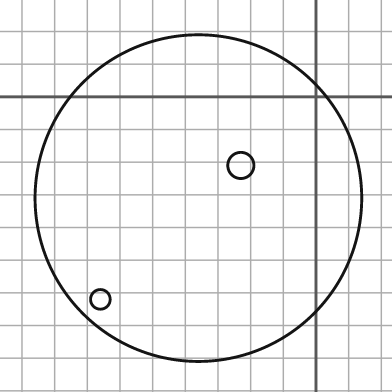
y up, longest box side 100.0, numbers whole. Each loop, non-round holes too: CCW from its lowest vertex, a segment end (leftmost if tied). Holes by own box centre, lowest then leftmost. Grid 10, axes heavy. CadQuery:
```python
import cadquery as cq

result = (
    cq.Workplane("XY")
    .moveTo(-36.0, -31.0)
    .circle(50.0)
    .moveTo(-66.0, -62.0)
    .circle(3.0)
    .moveTo(-23.0, -21.0)
    .circle(4.0)
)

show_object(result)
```